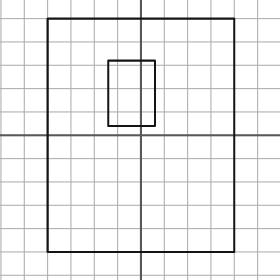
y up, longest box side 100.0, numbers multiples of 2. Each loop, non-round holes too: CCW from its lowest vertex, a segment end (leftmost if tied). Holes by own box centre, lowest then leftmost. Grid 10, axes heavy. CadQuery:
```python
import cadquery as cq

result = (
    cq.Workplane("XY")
    .moveTo(-40.0, -50.0)
    .lineTo(40.0, -50.0)
    .lineTo(40.0, 50.0)
    .lineTo(-40.0, 50.0)
    .close()
    .moveTo(-14.0, 4.0)
    .lineTo(6.0, 4.0)
    .lineTo(6.0, 32.0)
    .lineTo(-14.0, 32.0)
    .close()
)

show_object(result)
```